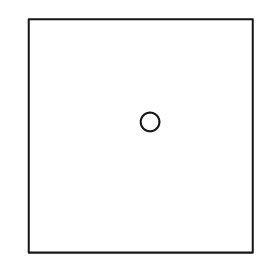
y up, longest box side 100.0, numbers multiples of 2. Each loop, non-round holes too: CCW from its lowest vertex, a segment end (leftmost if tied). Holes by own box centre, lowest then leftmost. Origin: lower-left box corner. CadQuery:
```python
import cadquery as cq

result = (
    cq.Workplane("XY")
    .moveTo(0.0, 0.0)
    .lineTo(96.0, 0.0)
    .lineTo(96.0, 100.0)
    .lineTo(0.0, 100.0)
    .close()
    .moveTo(52.0, 56.0)
    .circle(4.0)
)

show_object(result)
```